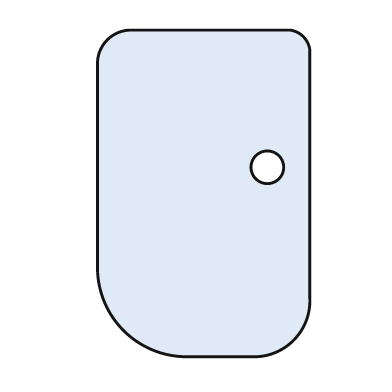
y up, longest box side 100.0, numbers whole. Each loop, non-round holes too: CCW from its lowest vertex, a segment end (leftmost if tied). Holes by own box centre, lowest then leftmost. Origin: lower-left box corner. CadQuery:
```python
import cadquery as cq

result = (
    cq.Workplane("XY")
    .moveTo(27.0, 0.0)
    .lineTo(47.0, 0.0)
    .threePointArc((60.0, 5.0), (65.0, 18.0))
    .lineTo(65.0, 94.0)
    .threePointArc((63.0, 98.0), (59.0, 100.0))
    .lineTo(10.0, 100.0)
    .threePointArc((3.0, 97.0), (0.0, 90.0))
    .lineTo(0.0, 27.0)
    .threePointArc((8.0, 8.0), (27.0, 0.0))
    .close()
    .moveTo(52.0, 58.0)
    .circle(5.0)
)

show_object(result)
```